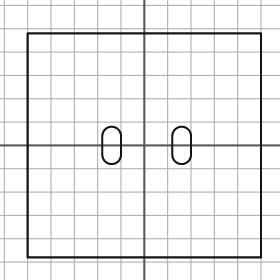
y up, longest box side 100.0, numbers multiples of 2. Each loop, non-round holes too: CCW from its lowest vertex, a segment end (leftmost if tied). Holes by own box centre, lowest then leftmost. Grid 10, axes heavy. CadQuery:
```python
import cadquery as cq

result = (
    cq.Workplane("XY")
    .moveTo(-50.0, -48.0)
    .lineTo(50.0, -48.0)
    .lineTo(50.0, 48.0)
    .lineTo(-50.0, 48.0)
    .close()
    .moveTo(-18.0, -4.0)
    .threePointArc((-14.0, -8.0), (-10.0, -4.0))
    .lineTo(-10.0, 4.0)
    .threePointArc((-14.0, 8.0), (-18.0, 4.0))
    .close()
    .moveTo(12.0, -4.0)
    .threePointArc((16.0, -8.0), (20.0, -4.0))
    .lineTo(20.0, 4.0)
    .threePointArc((16.0, 8.0), (12.0, 4.0))
    .close()
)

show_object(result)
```